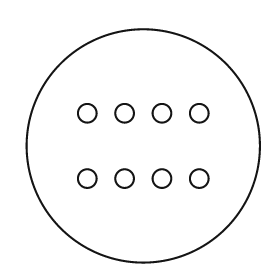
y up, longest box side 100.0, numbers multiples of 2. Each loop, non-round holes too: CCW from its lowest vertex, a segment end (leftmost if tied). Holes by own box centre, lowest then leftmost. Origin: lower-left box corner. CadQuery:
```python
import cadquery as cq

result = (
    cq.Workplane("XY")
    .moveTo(50.0, 50.0)
    .circle(50.0)
    .moveTo(26.0, 36.0)
    .circle(4.0)
    .moveTo(42.0, 36.0)
    .circle(4.0)
    .moveTo(58.0, 36.0)
    .circle(4.0)
    .moveTo(74.0, 36.0)
    .circle(4.0)
    .moveTo(26.0, 64.0)
    .circle(4.0)
    .moveTo(42.0, 64.0)
    .circle(4.0)
    .moveTo(58.0, 64.0)
    .circle(4.0)
    .moveTo(74.0, 64.0)
    .circle(4.0)
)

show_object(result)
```